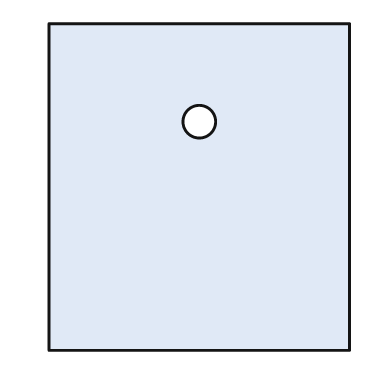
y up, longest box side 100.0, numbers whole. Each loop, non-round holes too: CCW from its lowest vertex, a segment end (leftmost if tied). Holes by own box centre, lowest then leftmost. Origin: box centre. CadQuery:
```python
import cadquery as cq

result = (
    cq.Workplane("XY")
    .moveTo(-46.0, -50.0)
    .lineTo(46.0, -50.0)
    .lineTo(46.0, 50.0)
    .lineTo(-46.0, 50.0)
    .close()
    .moveTo(0.0, 20.0)
    .circle(5.0)
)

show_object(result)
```